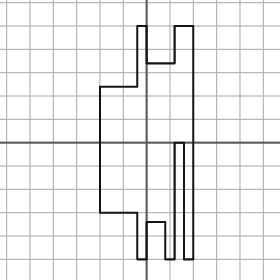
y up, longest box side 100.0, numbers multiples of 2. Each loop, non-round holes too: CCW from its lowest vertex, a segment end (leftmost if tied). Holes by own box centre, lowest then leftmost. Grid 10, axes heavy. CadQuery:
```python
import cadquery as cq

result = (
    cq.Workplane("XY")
    .moveTo(-4.0, -50.0)
    .lineTo(0.0, -50.0)
    .lineTo(0.0, -34.0)
    .lineTo(8.0, -34.0)
    .lineTo(8.0, -50.0)
    .lineTo(12.0, -50.0)
    .lineTo(12.0, 0.0)
    .lineTo(16.0, 0.0)
    .lineTo(16.0, -50.0)
    .lineTo(20.0, -50.0)
    .lineTo(20.0, 50.0)
    .lineTo(12.0, 50.0)
    .lineTo(12.0, 34.0)
    .lineTo(0.0, 34.0)
    .lineTo(0.0, 50.0)
    .lineTo(-4.0, 50.0)
    .lineTo(-4.0, 24.0)
    .lineTo(-20.0, 24.0)
    .lineTo(-20.0, -30.0)
    .lineTo(-4.0, -30.0)
    .close()
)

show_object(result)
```